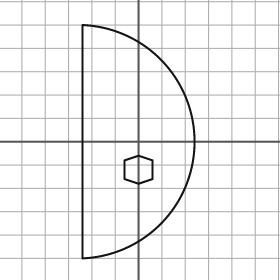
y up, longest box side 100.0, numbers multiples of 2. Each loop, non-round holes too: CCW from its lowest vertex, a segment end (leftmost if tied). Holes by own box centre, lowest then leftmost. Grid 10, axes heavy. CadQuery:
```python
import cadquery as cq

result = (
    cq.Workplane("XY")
    .moveTo(-24.0, -50.0)
    .threePointArc((24.0, 0.0), (-24.0, 50.0))
    .close()
    .moveTo(0.0, -18.0)
    .lineTo(6.0, -16.0)
    .lineTo(6.0, -8.0)
    .lineTo(0.0, -6.0)
    .lineTo(-6.0, -8.0)
    .lineTo(-6.0, -16.0)
    .close()
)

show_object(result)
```